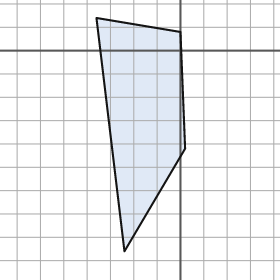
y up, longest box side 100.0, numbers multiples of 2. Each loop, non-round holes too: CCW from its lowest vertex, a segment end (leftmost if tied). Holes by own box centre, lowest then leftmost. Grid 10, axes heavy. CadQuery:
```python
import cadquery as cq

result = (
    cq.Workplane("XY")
    .moveTo(-24.0, -86.0)
    .lineTo(2.0, -42.0)
    .lineTo(0.0, 8.0)
    .lineTo(-36.0, 14.0)
    .close()
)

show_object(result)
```